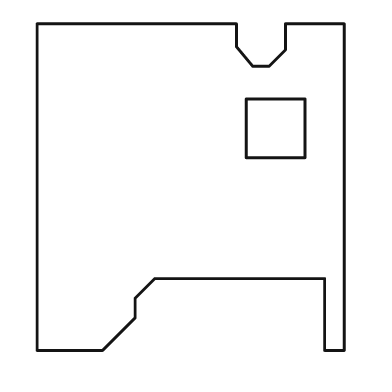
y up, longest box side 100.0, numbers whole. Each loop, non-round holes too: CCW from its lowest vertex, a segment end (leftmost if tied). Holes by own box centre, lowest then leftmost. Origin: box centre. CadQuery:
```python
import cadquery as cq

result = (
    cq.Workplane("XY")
    .moveTo(-47.0, -50.0)
    .lineTo(-27.0, -50.0)
    .lineTo(-17.0, -40.0)
    .lineTo(-17.0, -34.0)
    .lineTo(-11.0, -28.0)
    .lineTo(41.0, -28.0)
    .lineTo(41.0, -50.0)
    .lineTo(47.0, -50.0)
    .lineTo(47.0, 50.0)
    .lineTo(29.0, 50.0)
    .lineTo(29.0, 42.0)
    .lineTo(24.0, 37.0)
    .lineTo(19.0, 37.0)
    .lineTo(14.0, 43.0)
    .lineTo(14.0, 50.0)
    .lineTo(-47.0, 50.0)
    .close()
    .moveTo(17.0, 9.0)
    .lineTo(35.0, 9.0)
    .lineTo(35.0, 27.0)
    .lineTo(17.0, 27.0)
    .close()
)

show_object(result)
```